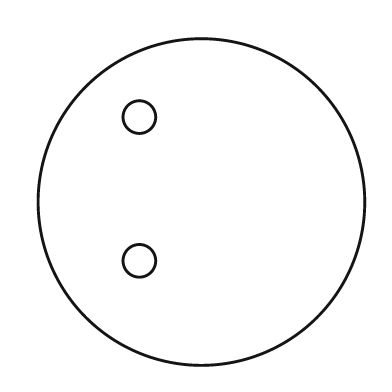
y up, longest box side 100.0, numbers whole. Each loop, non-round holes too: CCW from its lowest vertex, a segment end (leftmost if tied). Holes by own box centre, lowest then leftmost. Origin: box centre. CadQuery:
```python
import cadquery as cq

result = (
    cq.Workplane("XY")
    .moveTo(0.0, 0.0)
    .circle(50.0)
    .moveTo(-19.0, -18.0)
    .circle(5.0)
    .moveTo(-19.0, 26.0)
    .circle(5.0)
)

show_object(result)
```